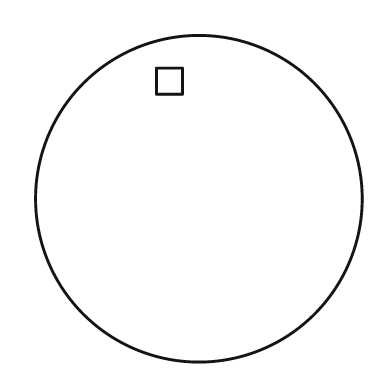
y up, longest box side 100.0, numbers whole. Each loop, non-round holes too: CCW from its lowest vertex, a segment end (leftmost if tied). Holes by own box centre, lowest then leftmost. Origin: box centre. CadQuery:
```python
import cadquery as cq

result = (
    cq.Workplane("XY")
    .moveTo(0.0, 0.0)
    .circle(50.0)
    .moveTo(-13.0, 32.0)
    .lineTo(-5.0, 32.0)
    .lineTo(-5.0, 40.0)
    .lineTo(-13.0, 40.0)
    .close()
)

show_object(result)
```